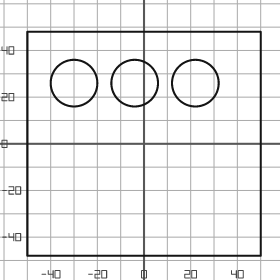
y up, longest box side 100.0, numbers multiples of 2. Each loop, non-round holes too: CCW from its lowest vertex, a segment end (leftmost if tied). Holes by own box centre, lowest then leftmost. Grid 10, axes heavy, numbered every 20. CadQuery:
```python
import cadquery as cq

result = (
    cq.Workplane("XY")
    .moveTo(-50.0, -48.0)
    .lineTo(50.0, -48.0)
    .lineTo(50.0, 48.0)
    .lineTo(-50.0, 48.0)
    .close()
    .moveTo(-30.0, 26.0)
    .circle(10.0)
    .moveTo(-4.0, 26.0)
    .circle(10.0)
    .moveTo(22.0, 26.0)
    .circle(10.0)
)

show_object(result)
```